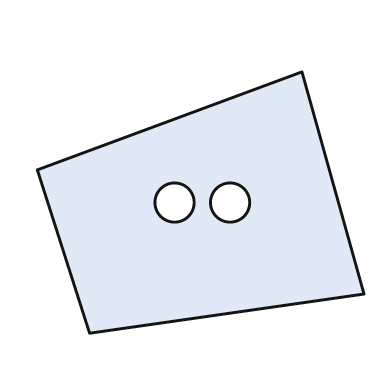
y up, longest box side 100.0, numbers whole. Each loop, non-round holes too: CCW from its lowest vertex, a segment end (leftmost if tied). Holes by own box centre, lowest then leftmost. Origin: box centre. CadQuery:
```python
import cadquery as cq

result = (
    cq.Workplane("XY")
    .moveTo(-34.0, -40.0)
    .lineTo(50.0, -28.0)
    .lineTo(31.0, 40.0)
    .lineTo(-50.0, 10.0)
    .close()
    .moveTo(-8.0, 0.0)
    .circle(6.0)
    .moveTo(9.0, 0.0)
    .circle(6.0)
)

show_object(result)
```